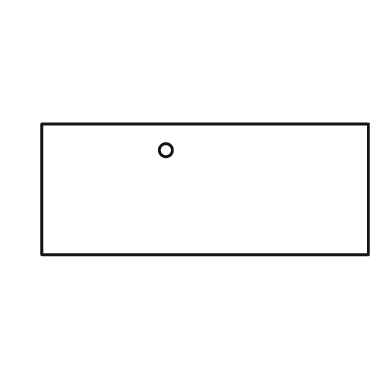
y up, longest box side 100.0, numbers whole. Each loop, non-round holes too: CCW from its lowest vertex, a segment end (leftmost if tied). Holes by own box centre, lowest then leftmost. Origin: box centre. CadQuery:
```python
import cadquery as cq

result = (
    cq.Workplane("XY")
    .moveTo(-50.0, -20.0)
    .lineTo(50.0, -20.0)
    .lineTo(50.0, 20.0)
    .lineTo(-50.0, 20.0)
    .close()
    .moveTo(-12.0, 12.0)
    .circle(2.0)
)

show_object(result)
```